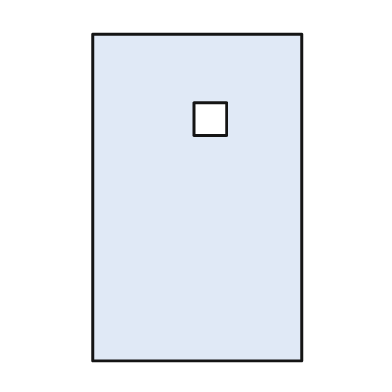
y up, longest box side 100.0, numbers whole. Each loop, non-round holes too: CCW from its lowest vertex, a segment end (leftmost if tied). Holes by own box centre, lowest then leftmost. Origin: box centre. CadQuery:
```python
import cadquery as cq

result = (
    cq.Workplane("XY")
    .moveTo(-32.0, -50.0)
    .lineTo(32.0, -50.0)
    .lineTo(32.0, 50.0)
    .lineTo(-32.0, 50.0)
    .close()
    .moveTo(-1.0, 19.0)
    .lineTo(9.0, 19.0)
    .lineTo(9.0, 29.0)
    .lineTo(-1.0, 29.0)
    .close()
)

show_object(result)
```